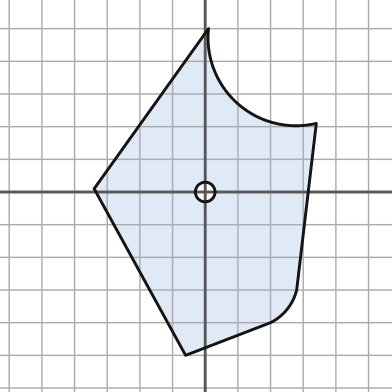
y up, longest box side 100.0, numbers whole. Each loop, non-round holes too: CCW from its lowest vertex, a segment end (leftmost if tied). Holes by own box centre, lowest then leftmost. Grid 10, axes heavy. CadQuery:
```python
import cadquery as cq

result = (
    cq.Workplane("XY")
    .moveTo(-6.0, -50.0)
    .lineTo(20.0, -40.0)
    .threePointArc((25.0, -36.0), (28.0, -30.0))
    .lineTo(34.0, 21.0)
    .threePointArc((10.0, 27.0), (1.0, 50.0))
    .lineTo(-34.0, 1.0)
    .close()
    .moveTo(0.0, 0.0)
    .circle(3.0)
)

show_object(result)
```